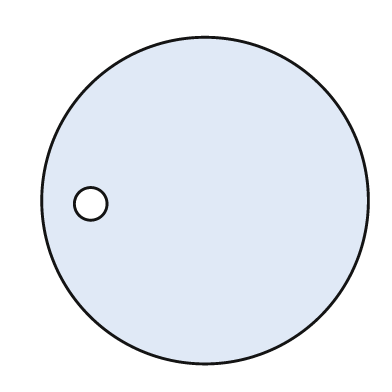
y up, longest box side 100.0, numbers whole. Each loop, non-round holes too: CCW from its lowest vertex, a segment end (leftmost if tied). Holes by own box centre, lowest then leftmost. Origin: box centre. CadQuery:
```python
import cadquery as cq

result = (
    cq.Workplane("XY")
    .moveTo(0.0, 0.0)
    .circle(50.0)
    .moveTo(-35.0, -1.0)
    .circle(5.0)
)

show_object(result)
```